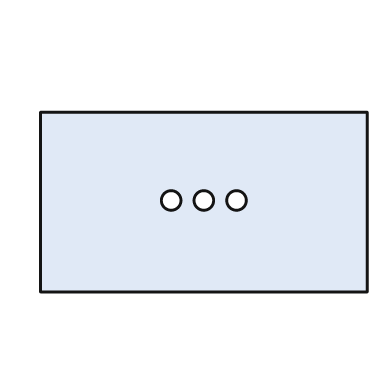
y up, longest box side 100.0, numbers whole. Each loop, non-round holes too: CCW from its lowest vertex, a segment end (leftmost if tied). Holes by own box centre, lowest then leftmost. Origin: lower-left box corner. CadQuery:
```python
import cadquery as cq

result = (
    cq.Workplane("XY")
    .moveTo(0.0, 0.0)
    .lineTo(100.0, 0.0)
    .lineTo(100.0, 55.0)
    .lineTo(0.0, 55.0)
    .close()
    .moveTo(40.0, 28.0)
    .circle(3.0)
    .moveTo(50.0, 28.0)
    .circle(3.0)
    .moveTo(60.0, 28.0)
    .circle(3.0)
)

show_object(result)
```